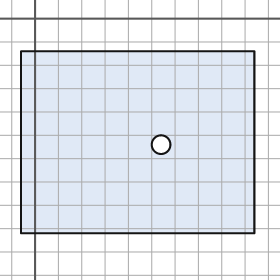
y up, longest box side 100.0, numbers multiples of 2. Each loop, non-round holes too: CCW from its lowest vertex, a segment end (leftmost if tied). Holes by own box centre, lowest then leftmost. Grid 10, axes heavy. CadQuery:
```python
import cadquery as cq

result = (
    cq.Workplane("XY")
    .moveTo(-6.0, -92.0)
    .lineTo(94.0, -92.0)
    .lineTo(94.0, -14.0)
    .lineTo(-6.0, -14.0)
    .close()
    .moveTo(54.0, -54.0)
    .circle(4.0)
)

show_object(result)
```